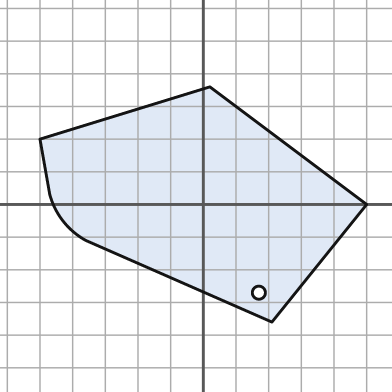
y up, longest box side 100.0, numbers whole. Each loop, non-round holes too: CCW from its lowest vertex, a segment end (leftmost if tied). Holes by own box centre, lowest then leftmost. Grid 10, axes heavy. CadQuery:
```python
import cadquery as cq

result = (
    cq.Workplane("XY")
    .moveTo(21.0, -36.0)
    .lineTo(50.0, 0.0)
    .lineTo(2.0, 36.0)
    .lineTo(-50.0, 20.0)
    .lineTo(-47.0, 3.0)
    .threePointArc((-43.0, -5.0), (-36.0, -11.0))
    .close()
    .moveTo(17.0, -27.0)
    .circle(2.0)
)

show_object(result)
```